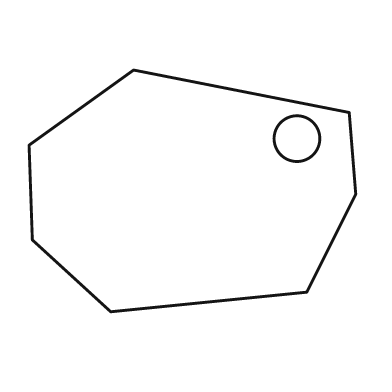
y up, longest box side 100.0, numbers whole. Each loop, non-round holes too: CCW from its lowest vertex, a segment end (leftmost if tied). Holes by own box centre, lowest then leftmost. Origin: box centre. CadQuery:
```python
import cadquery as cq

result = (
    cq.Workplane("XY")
    .moveTo(-25.0, -37.0)
    .lineTo(35.0, -31.0)
    .lineTo(50.0, -1.0)
    .lineTo(48.0, 24.0)
    .lineTo(-18.0, 37.0)
    .lineTo(-50.0, 14.0)
    .lineTo(-49.0, -15.0)
    .close()
    .moveTo(32.0, 16.0)
    .circle(7.0)
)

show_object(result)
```